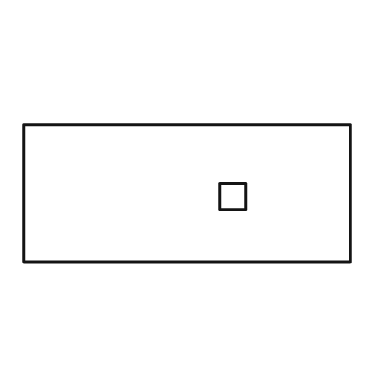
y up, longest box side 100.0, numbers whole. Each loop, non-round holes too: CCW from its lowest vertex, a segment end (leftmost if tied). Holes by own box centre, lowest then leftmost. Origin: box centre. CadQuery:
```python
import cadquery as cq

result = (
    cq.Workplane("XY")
    .moveTo(-50.0, -21.0)
    .lineTo(50.0, -21.0)
    .lineTo(50.0, 21.0)
    .lineTo(-50.0, 21.0)
    .close()
    .moveTo(10.0, -5.0)
    .lineTo(18.0, -5.0)
    .lineTo(18.0, 3.0)
    .lineTo(10.0, 3.0)
    .close()
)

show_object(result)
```